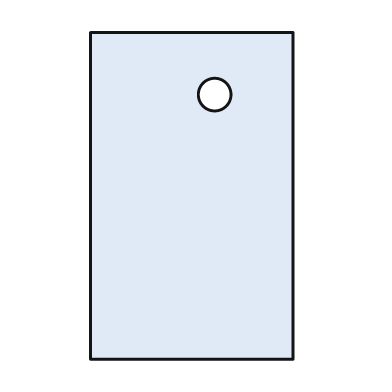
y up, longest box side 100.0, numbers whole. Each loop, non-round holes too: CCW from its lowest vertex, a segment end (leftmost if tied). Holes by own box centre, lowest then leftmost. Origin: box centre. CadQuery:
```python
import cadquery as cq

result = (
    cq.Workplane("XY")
    .moveTo(-31.0, -50.0)
    .lineTo(31.0, -50.0)
    .lineTo(31.0, 50.0)
    .lineTo(-31.0, 50.0)
    .close()
    .moveTo(7.0, 31.0)
    .circle(5.0)
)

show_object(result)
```